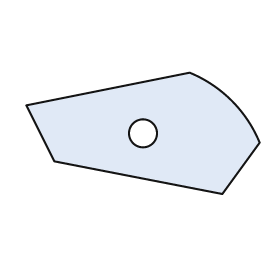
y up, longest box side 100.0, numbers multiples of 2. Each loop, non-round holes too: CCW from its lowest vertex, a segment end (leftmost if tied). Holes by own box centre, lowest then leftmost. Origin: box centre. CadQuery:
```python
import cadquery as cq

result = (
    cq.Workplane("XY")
    .moveTo(34.0, -26.0)
    .lineTo(50.0, -4.0)
    .threePointArc((38.0, 14.0), (20.0, 26.0))
    .lineTo(-50.0, 12.0)
    .lineTo(-38.0, -12.0)
    .close()
    .moveTo(0.0, 0.0)
    .circle(6.0)
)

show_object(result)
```